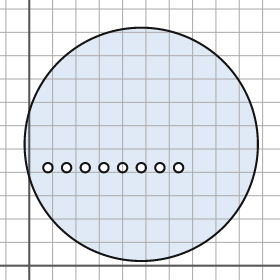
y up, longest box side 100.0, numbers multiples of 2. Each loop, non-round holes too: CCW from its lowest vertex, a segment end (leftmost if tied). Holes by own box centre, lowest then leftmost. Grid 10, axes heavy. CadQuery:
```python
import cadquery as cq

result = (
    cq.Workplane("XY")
    .moveTo(48.0, 52.0)
    .circle(50.0)
    .moveTo(8.0, 42.0)
    .circle(2.0)
    .moveTo(16.0, 42.0)
    .circle(2.0)
    .moveTo(24.0, 42.0)
    .circle(2.0)
    .moveTo(32.0, 42.0)
    .circle(2.0)
    .moveTo(40.0, 42.0)
    .circle(2.0)
    .moveTo(48.0, 42.0)
    .circle(2.0)
    .moveTo(56.0, 42.0)
    .circle(2.0)
    .moveTo(64.0, 42.0)
    .circle(2.0)
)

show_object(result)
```